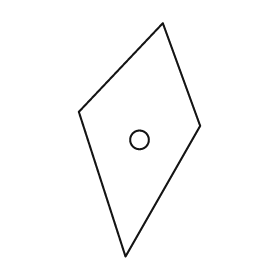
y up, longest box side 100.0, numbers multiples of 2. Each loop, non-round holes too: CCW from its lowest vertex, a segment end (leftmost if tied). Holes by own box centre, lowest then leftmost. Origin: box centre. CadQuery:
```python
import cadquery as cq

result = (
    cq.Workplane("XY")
    .moveTo(-6.0, -50.0)
    .lineTo(26.0, 6.0)
    .lineTo(10.0, 50.0)
    .lineTo(-26.0, 12.0)
    .close()
    .moveTo(0.0, 0.0)
    .circle(4.0)
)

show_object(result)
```